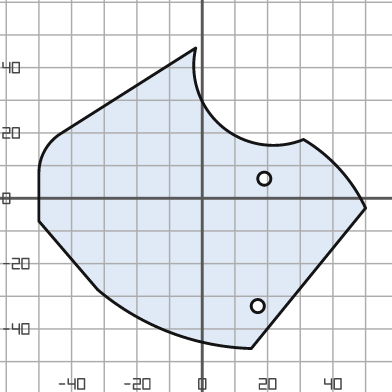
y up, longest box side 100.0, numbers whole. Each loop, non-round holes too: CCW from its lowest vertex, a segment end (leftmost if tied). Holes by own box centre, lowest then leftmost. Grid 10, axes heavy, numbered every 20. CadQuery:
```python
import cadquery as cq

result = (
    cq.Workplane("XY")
    .moveTo(15.0, -46.0)
    .lineTo(50.0, -3.0)
    .threePointArc((42.0, 9.0), (31.0, 18.0))
    .threePointArc((6.0, 22.0), (-2.0, 46.0))
    .lineTo(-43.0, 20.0)
    .threePointArc((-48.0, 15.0), (-50.0, 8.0))
    .lineTo(-50.0, -7.0)
    .lineTo(-32.0, -28.0)
    .threePointArc((-10.0, -41.0), (15.0, -46.0))
    .close()
    .moveTo(17.0, -33.0)
    .circle(2.0)
    .moveTo(19.0, 6.0)
    .circle(2.0)
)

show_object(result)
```